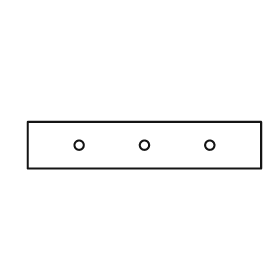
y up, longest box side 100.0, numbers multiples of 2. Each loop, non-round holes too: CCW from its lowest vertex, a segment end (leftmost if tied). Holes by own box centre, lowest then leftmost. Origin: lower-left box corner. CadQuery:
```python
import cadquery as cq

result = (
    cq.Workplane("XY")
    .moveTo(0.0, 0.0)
    .lineTo(100.0, 0.0)
    .lineTo(100.0, 20.0)
    .lineTo(0.0, 20.0)
    .close()
    .moveTo(22.0, 10.0)
    .circle(2.0)
    .moveTo(50.0, 10.0)
    .circle(2.0)
    .moveTo(78.0, 10.0)
    .circle(2.0)
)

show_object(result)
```